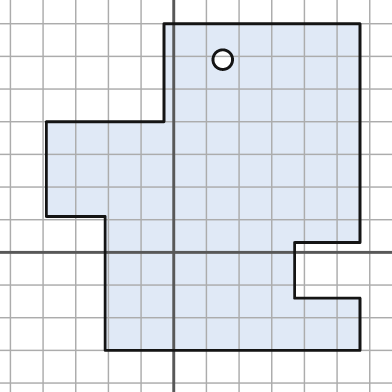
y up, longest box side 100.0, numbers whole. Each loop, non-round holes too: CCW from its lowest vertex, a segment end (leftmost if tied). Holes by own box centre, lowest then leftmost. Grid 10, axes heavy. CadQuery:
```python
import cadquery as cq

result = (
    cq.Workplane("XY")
    .moveTo(-21.0, -30.0)
    .lineTo(57.0, -30.0)
    .lineTo(57.0, -14.0)
    .lineTo(37.0, -14.0)
    .lineTo(37.0, 3.0)
    .lineTo(57.0, 3.0)
    .lineTo(57.0, 70.0)
    .lineTo(-3.0, 70.0)
    .lineTo(-3.0, 40.0)
    .lineTo(-39.0, 40.0)
    .lineTo(-39.0, 11.0)
    .lineTo(-21.0, 11.0)
    .close()
    .moveTo(15.0, 59.0)
    .circle(3.0)
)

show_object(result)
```